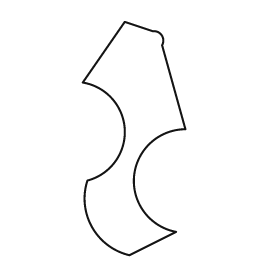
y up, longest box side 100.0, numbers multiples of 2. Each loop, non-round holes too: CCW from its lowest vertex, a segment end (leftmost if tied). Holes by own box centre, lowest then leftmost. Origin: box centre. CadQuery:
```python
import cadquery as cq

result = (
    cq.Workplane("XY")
    .moveTo(-2.0, -50.0)
    .lineTo(18.0, -40.0)
    .threePointArc((0.0, -16.0), (22.0, 4.0))
    .lineTo(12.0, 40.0)
    .threePointArc((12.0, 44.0), (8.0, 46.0))
    .lineTo(-4.0, 50.0)
    .lineTo(-22.0, 24.0)
    .threePointArc((-4.0, 4.0), (-20.0, -18.0))
    .threePointArc((-18.0, -38.0), (-2.0, -50.0))
    .close()
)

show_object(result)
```